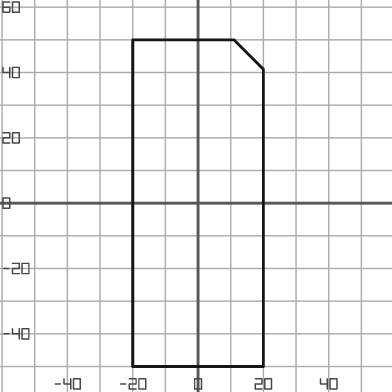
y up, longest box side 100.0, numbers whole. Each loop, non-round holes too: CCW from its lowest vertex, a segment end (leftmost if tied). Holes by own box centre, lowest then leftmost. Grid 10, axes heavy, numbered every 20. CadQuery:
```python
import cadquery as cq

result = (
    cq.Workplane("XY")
    .moveTo(-20.0, -50.0)
    .lineTo(20.0, -50.0)
    .lineTo(20.0, 41.0)
    .lineTo(11.0, 50.0)
    .lineTo(-20.0, 50.0)
    .close()
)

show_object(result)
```